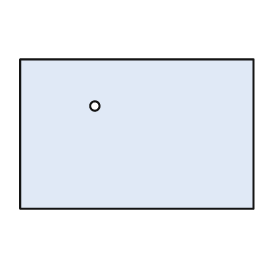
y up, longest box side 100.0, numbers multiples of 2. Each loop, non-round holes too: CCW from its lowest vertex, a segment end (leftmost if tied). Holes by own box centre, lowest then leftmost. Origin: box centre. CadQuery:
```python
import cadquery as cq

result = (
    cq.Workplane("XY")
    .moveTo(-50.0, -32.0)
    .lineTo(50.0, -32.0)
    .lineTo(50.0, 32.0)
    .lineTo(-50.0, 32.0)
    .close()
    .moveTo(-18.0, 12.0)
    .circle(2.0)
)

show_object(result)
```